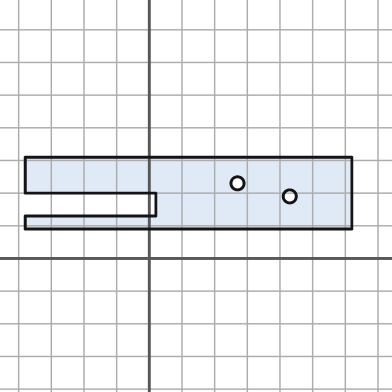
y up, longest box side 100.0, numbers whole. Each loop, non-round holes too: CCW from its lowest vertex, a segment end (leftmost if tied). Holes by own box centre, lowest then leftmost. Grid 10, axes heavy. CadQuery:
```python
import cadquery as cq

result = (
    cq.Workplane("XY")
    .moveTo(-38.0, 9.0)
    .lineTo(62.0, 9.0)
    .lineTo(62.0, 31.0)
    .lineTo(-38.0, 31.0)
    .lineTo(-38.0, 20.0)
    .lineTo(2.0, 20.0)
    .lineTo(2.0, 13.0)
    .lineTo(-38.0, 13.0)
    .close()
    .moveTo(43.0, 19.0)
    .circle(2.0)
    .moveTo(27.0, 23.0)
    .circle(2.0)
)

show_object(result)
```